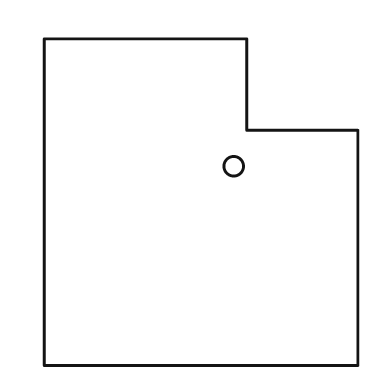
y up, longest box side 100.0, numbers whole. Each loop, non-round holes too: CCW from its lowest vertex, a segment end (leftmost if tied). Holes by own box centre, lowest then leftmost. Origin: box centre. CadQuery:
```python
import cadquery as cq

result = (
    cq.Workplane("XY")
    .moveTo(-48.0, -50.0)
    .lineTo(48.0, -50.0)
    .lineTo(48.0, 22.0)
    .lineTo(14.0, 22.0)
    .lineTo(14.0, 50.0)
    .lineTo(-48.0, 50.0)
    .close()
    .moveTo(10.0, 11.0)
    .circle(3.0)
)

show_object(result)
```